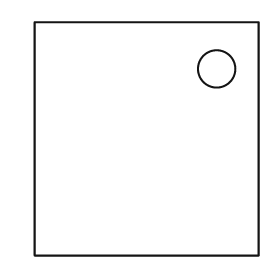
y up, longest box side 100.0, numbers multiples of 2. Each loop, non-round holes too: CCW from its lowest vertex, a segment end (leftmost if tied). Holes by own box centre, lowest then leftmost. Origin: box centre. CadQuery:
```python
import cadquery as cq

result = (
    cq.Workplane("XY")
    .moveTo(-48.0, -50.0)
    .lineTo(48.0, -50.0)
    .lineTo(48.0, 50.0)
    .lineTo(-48.0, 50.0)
    .close()
    .moveTo(30.0, 30.0)
    .circle(8.0)
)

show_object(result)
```